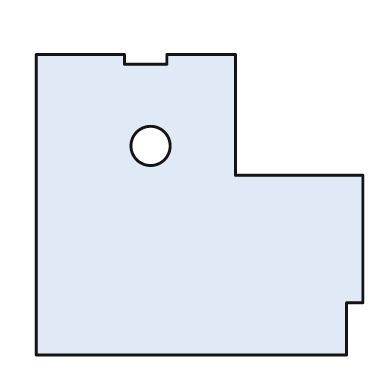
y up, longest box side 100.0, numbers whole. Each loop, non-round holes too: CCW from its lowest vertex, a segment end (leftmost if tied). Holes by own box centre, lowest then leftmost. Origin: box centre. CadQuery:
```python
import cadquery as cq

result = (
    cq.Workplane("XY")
    .moveTo(-50.0, -46.0)
    .lineTo(45.0, -46.0)
    .lineTo(45.0, -30.0)
    .lineTo(50.0, -30.0)
    .lineTo(50.0, 9.0)
    .lineTo(11.0, 9.0)
    .lineTo(11.0, 46.0)
    .lineTo(-10.0, 46.0)
    .lineTo(-10.0, 43.0)
    .lineTo(-23.0, 43.0)
    .lineTo(-23.0, 46.0)
    .lineTo(-50.0, 46.0)
    .close()
    .moveTo(-15.0, 18.0)
    .circle(6.0)
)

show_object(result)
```